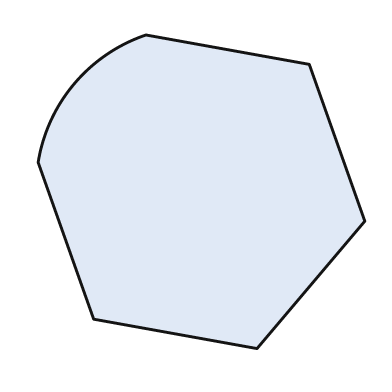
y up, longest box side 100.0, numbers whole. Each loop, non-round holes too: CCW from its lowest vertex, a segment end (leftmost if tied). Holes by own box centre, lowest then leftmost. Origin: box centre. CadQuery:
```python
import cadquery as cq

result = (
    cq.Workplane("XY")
    .moveTo(17.0, -48.0)
    .lineTo(50.0, -9.0)
    .lineTo(33.0, 39.0)
    .lineTo(-17.0, 48.0)
    .threePointArc((-39.0, 33.0), (-50.0, 9.0))
    .lineTo(-33.0, -39.0)
    .close()
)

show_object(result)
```